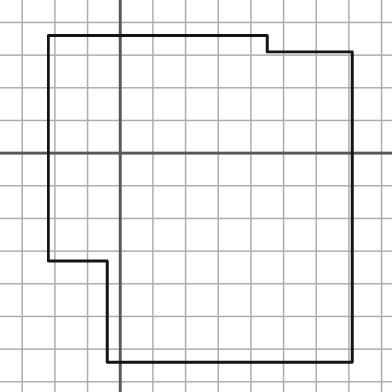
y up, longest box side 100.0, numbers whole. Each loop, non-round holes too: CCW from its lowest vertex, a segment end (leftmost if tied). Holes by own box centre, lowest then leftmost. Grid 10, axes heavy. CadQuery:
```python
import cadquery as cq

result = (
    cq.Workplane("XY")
    .moveTo(-4.0, -64.0)
    .lineTo(71.0, -64.0)
    .lineTo(71.0, 31.0)
    .lineTo(45.0, 31.0)
    .lineTo(45.0, 36.0)
    .lineTo(-22.0, 36.0)
    .lineTo(-22.0, -33.0)
    .lineTo(-4.0, -33.0)
    .close()
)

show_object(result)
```